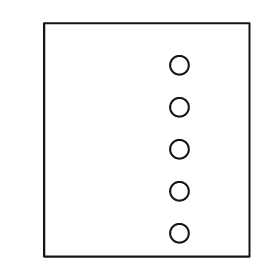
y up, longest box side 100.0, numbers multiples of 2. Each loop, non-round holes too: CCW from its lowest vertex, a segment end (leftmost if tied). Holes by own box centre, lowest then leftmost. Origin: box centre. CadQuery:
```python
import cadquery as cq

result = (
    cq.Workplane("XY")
    .moveTo(-44.0, -50.0)
    .lineTo(44.0, -50.0)
    .lineTo(44.0, 50.0)
    .lineTo(-44.0, 50.0)
    .close()
    .moveTo(14.0, -40.0)
    .circle(4.0)
    .moveTo(14.0, -22.0)
    .circle(4.0)
    .moveTo(14.0, -4.0)
    .circle(4.0)
    .moveTo(14.0, 14.0)
    .circle(4.0)
    .moveTo(14.0, 32.0)
    .circle(4.0)
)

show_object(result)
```